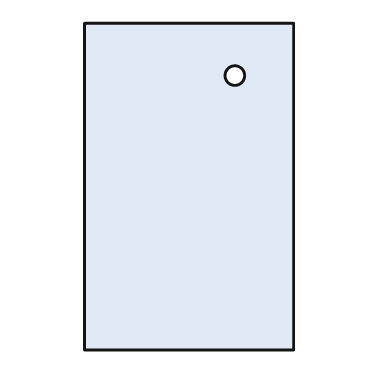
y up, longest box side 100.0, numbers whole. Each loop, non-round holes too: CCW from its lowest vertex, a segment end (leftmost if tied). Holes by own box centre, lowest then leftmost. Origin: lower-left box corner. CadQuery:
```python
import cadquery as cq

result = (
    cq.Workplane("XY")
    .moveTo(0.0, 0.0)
    .lineTo(64.0, 0.0)
    .lineTo(64.0, 100.0)
    .lineTo(0.0, 100.0)
    .close()
    .moveTo(46.0, 84.0)
    .circle(3.0)
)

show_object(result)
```